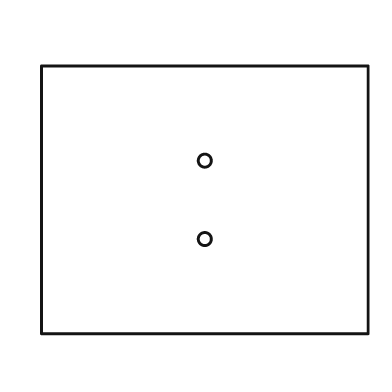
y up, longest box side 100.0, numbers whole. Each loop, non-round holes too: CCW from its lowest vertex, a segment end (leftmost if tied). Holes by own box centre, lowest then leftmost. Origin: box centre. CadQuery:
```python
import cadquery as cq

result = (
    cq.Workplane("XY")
    .moveTo(-50.0, -41.0)
    .lineTo(50.0, -41.0)
    .lineTo(50.0, 41.0)
    .lineTo(-50.0, 41.0)
    .close()
    .moveTo(0.0, -12.0)
    .circle(2.0)
    .moveTo(0.0, 12.0)
    .circle(2.0)
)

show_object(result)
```